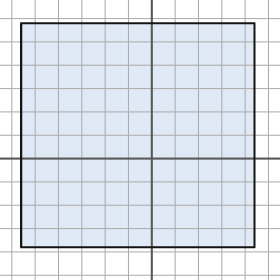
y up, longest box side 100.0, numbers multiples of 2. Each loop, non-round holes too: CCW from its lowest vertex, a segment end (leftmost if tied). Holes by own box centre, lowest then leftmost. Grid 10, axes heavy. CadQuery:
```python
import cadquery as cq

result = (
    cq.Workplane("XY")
    .moveTo(-56.0, -38.0)
    .lineTo(44.0, -38.0)
    .lineTo(44.0, 58.0)
    .lineTo(-56.0, 58.0)
    .close()
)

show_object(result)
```